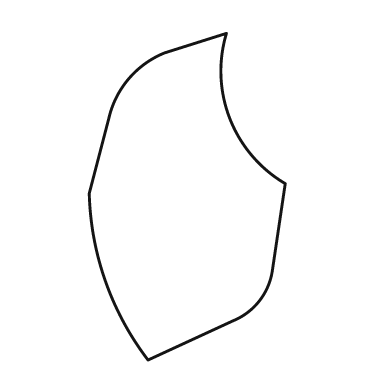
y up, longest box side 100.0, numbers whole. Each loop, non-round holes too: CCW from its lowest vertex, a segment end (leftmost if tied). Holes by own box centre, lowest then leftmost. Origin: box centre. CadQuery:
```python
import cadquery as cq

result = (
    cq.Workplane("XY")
    .moveTo(-12.0, -50.0)
    .lineTo(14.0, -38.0)
    .threePointArc((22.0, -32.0), (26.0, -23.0))
    .lineTo(30.0, 4.0)
    .threePointArc((13.0, 24.0), (12.0, 50.0))
    .lineTo(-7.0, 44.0)
    .threePointArc((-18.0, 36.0), (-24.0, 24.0))
    .lineTo(-30.0, 1.0)
    .threePointArc((-25.0, -26.0), (-12.0, -50.0))
    .close()
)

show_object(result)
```